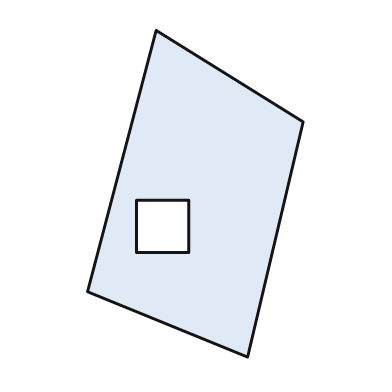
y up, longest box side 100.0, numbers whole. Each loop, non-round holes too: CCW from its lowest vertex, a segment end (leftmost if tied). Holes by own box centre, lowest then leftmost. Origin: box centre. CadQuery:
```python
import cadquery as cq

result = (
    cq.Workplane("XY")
    .moveTo(16.0, -50.0)
    .lineTo(33.0, 22.0)
    .lineTo(-12.0, 50.0)
    .lineTo(-33.0, -30.0)
    .close()
    .moveTo(-18.0, -18.0)
    .lineTo(-2.0, -18.0)
    .lineTo(-2.0, -2.0)
    .lineTo(-18.0, -2.0)
    .close()
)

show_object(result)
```